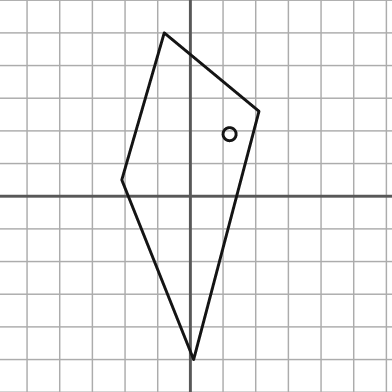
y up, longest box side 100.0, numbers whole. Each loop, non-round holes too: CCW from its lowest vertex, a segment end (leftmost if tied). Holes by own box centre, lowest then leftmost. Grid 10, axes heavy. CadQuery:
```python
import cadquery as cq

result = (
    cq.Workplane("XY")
    .moveTo(1.0, -50.0)
    .lineTo(21.0, 26.0)
    .lineTo(-8.0, 50.0)
    .lineTo(-21.0, 5.0)
    .close()
    .moveTo(12.0, 19.0)
    .circle(2.0)
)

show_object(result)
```